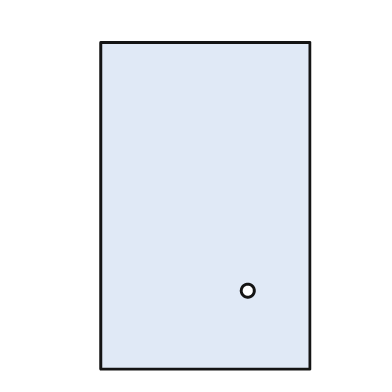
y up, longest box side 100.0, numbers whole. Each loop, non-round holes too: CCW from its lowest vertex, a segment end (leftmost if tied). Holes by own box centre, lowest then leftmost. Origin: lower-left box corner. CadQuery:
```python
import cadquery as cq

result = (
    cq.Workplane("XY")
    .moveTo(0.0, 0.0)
    .lineTo(64.0, 0.0)
    .lineTo(64.0, 100.0)
    .lineTo(0.0, 100.0)
    .close()
    .moveTo(45.0, 24.0)
    .circle(2.0)
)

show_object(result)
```